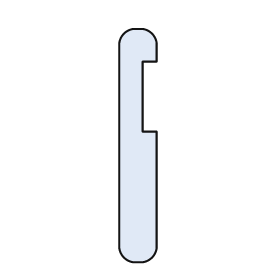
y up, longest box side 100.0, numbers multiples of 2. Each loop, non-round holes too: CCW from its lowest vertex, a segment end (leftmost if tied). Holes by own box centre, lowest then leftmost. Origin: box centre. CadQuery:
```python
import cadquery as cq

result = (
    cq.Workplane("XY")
    .moveTo(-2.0, -50.0)
    .lineTo(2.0, -50.0)
    .threePointArc((6.0, -48.0), (8.0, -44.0))
    .lineTo(8.0, 6.0)
    .lineTo(2.0, 6.0)
    .lineTo(2.0, 36.0)
    .lineTo(8.0, 36.0)
    .lineTo(8.0, 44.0)
    .threePointArc((6.0, 48.0), (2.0, 50.0))
    .lineTo(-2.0, 50.0)
    .threePointArc((-6.0, 48.0), (-8.0, 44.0))
    .lineTo(-8.0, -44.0)
    .threePointArc((-6.0, -48.0), (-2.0, -50.0))
    .close()
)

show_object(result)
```